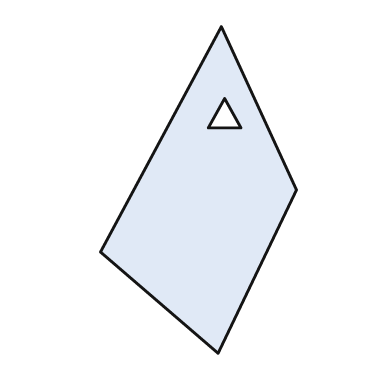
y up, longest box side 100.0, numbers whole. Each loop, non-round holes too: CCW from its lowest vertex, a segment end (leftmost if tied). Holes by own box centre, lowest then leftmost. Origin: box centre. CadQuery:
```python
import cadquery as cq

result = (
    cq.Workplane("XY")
    .moveTo(6.0, -50.0)
    .lineTo(30.0, 0.0)
    .lineTo(7.0, 50.0)
    .lineTo(-30.0, -19.0)
    .close()
    .moveTo(3.0, 19.0)
    .lineTo(13.0, 19.0)
    .lineTo(8.0, 28.0)
    .close()
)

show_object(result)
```